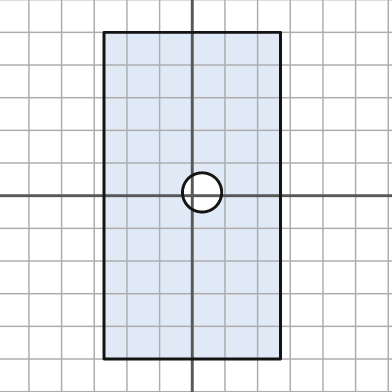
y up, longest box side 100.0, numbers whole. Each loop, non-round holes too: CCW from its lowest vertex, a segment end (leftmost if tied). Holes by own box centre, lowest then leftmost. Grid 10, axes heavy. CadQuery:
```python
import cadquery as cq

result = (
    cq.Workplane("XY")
    .moveTo(-27.0, -50.0)
    .lineTo(27.0, -50.0)
    .lineTo(27.0, 50.0)
    .lineTo(-27.0, 50.0)
    .close()
    .moveTo(3.0, 1.0)
    .circle(6.0)
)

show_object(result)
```